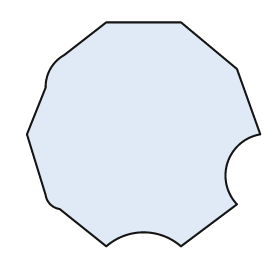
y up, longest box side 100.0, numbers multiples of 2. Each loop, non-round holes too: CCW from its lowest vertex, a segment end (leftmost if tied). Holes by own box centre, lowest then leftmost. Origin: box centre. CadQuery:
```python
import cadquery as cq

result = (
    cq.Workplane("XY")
    .moveTo(-16.0, -48.0)
    .threePointArc((0.0, -42.0), (16.0, -48.0))
    .lineTo(40.0, -30.0)
    .threePointArc((36.0, -12.0), (50.0, 0.0))
    .lineTo(40.0, 28.0)
    .lineTo(16.0, 48.0)
    .lineTo(-16.0, 48.0)
    .lineTo(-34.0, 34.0)
    .threePointArc((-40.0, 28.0), (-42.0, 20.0))
    .lineTo(-50.0, 0.0)
    .lineTo(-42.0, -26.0)
    .threePointArc((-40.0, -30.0), (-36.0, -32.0))
    .close()
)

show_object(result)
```